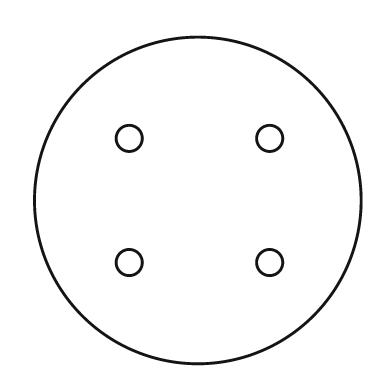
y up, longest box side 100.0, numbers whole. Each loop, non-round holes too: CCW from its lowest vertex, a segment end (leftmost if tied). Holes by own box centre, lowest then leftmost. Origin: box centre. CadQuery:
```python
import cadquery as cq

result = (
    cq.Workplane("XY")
    .moveTo(0.0, 0.0)
    .circle(50.0)
    .moveTo(-21.0, -19.0)
    .circle(4.0)
    .moveTo(22.0, -19.0)
    .circle(4.0)
    .moveTo(-21.0, 19.0)
    .circle(4.0)
    .moveTo(22.0, 19.0)
    .circle(4.0)
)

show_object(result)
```